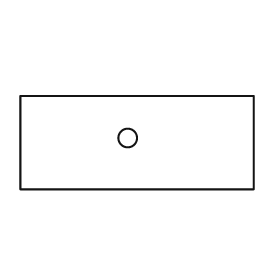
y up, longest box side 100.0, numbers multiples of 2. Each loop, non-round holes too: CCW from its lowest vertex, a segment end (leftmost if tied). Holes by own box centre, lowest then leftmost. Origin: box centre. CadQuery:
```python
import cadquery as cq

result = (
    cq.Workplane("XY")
    .moveTo(-50.0, -20.0)
    .lineTo(50.0, -20.0)
    .lineTo(50.0, 20.0)
    .lineTo(-50.0, 20.0)
    .close()
    .moveTo(-4.0, 2.0)
    .circle(4.0)
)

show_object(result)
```